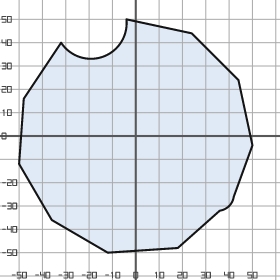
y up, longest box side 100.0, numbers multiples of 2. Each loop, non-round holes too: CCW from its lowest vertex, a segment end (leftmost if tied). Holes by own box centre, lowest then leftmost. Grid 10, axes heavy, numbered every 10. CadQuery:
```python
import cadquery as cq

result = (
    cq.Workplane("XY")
    .moveTo(-12.0, -50.0)
    .lineTo(18.0, -48.0)
    .lineTo(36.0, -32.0)
    .threePointArc((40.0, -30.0), (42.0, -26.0))
    .lineTo(50.0, -4.0)
    .lineTo(44.0, 24.0)
    .lineTo(24.0, 44.0)
    .lineTo(-4.0, 50.0)
    .threePointArc((-14.0, 34.0), (-32.0, 40.0))
    .lineTo(-48.0, 16.0)
    .lineTo(-50.0, -12.0)
    .lineTo(-36.0, -36.0)
    .close()
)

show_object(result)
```